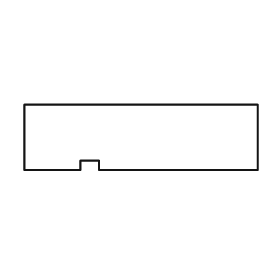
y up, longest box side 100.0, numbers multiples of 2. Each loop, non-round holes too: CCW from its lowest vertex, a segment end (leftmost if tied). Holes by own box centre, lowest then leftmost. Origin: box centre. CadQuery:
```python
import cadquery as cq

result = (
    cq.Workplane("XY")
    .moveTo(-50.0, -14.0)
    .lineTo(-26.0, -14.0)
    .lineTo(-26.0, -10.0)
    .lineTo(-18.0, -10.0)
    .lineTo(-18.0, -14.0)
    .lineTo(50.0, -14.0)
    .lineTo(50.0, 14.0)
    .lineTo(-50.0, 14.0)
    .close()
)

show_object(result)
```